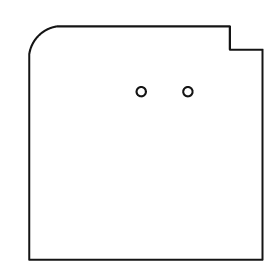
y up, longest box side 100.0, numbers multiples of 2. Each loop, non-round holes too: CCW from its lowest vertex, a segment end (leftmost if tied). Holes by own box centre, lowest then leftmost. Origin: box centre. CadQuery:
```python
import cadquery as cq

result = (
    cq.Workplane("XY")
    .moveTo(-50.0, -50.0)
    .lineTo(50.0, -50.0)
    .lineTo(50.0, 40.0)
    .lineTo(36.0, 40.0)
    .lineTo(36.0, 50.0)
    .lineTo(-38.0, 50.0)
    .threePointArc((-46.0, 46.0), (-50.0, 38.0))
    .close()
    .moveTo(-2.0, 22.0)
    .circle(2.0)
    .moveTo(18.0, 22.0)
    .circle(2.0)
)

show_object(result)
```